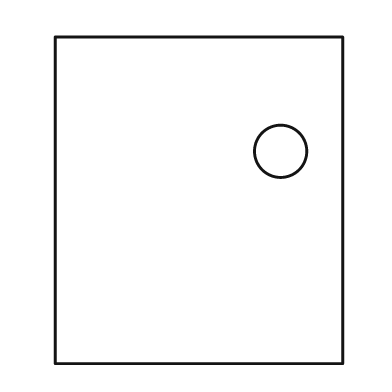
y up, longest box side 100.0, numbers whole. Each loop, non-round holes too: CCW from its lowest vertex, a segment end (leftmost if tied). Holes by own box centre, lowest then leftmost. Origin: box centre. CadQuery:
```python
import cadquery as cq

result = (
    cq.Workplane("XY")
    .moveTo(-44.0, -50.0)
    .lineTo(44.0, -50.0)
    .lineTo(44.0, 50.0)
    .lineTo(-44.0, 50.0)
    .close()
    .moveTo(25.0, 15.0)
    .circle(8.0)
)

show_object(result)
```